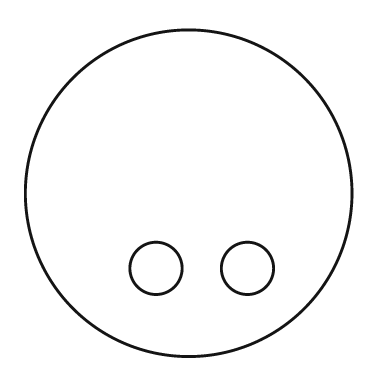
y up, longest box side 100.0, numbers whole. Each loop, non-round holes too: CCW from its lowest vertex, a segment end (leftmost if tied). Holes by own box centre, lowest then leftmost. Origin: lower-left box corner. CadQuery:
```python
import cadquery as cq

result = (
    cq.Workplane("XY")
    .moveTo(50.0, 50.0)
    .circle(50.0)
    .moveTo(40.0, 27.0)
    .circle(8.0)
    .moveTo(68.0, 27.0)
    .circle(8.0)
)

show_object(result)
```